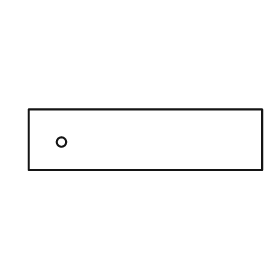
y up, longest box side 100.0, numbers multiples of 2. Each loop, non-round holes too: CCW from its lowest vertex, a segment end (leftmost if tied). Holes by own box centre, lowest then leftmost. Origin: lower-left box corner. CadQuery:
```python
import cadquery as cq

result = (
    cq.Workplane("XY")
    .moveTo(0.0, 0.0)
    .lineTo(100.0, 0.0)
    .lineTo(100.0, 26.0)
    .lineTo(0.0, 26.0)
    .close()
    .moveTo(14.0, 12.0)
    .circle(2.0)
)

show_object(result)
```